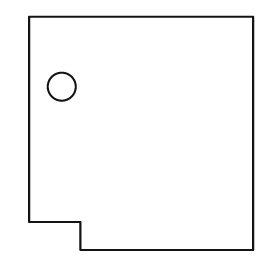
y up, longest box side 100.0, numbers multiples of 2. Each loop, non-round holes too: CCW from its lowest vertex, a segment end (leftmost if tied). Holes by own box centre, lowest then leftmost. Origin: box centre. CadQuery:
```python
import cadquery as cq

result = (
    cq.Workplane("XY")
    .moveTo(-26.0, -50.0)
    .lineTo(48.0, -50.0)
    .lineTo(48.0, 50.0)
    .lineTo(-48.0, 50.0)
    .lineTo(-48.0, -38.0)
    .lineTo(-26.0, -38.0)
    .close()
    .moveTo(-34.0, 20.0)
    .circle(6.0)
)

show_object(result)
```